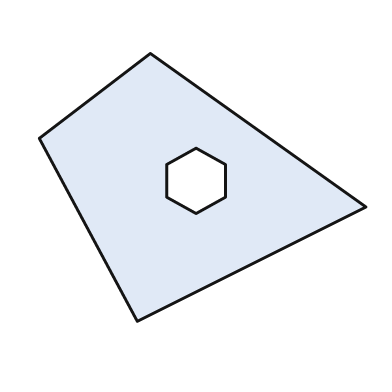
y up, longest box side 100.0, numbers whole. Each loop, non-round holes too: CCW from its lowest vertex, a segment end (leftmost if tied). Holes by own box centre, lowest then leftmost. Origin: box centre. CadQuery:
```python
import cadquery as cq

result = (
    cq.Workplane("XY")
    .moveTo(-20.0, -41.0)
    .lineTo(50.0, -6.0)
    .lineTo(-16.0, 41.0)
    .lineTo(-50.0, 15.0)
    .close()
    .moveTo(-2.0, -8.0)
    .lineTo(7.0, -3.0)
    .lineTo(7.0, 7.0)
    .lineTo(-2.0, 12.0)
    .lineTo(-11.0, 7.0)
    .lineTo(-11.0, -3.0)
    .close()
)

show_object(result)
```